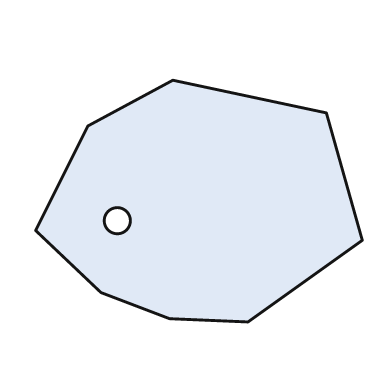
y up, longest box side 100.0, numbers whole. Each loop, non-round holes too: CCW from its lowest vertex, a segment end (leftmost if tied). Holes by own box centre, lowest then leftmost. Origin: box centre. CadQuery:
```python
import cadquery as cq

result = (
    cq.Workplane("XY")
    .moveTo(15.0, -37.0)
    .lineTo(50.0, -12.0)
    .lineTo(39.0, 27.0)
    .lineTo(-8.0, 37.0)
    .lineTo(-34.0, 23.0)
    .lineTo(-50.0, -9.0)
    .lineTo(-30.0, -28.0)
    .lineTo(-9.0, -36.0)
    .close()
    .moveTo(-25.0, -6.0)
    .circle(4.0)
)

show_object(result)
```